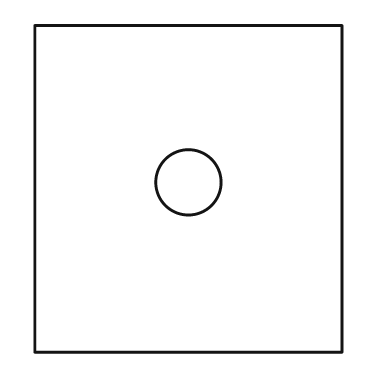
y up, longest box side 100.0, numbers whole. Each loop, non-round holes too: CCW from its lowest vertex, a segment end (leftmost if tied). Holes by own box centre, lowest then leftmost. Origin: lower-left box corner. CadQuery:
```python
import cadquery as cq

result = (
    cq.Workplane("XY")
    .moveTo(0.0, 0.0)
    .lineTo(94.0, 0.0)
    .lineTo(94.0, 100.0)
    .lineTo(0.0, 100.0)
    .close()
    .moveTo(47.0, 52.0)
    .circle(10.0)
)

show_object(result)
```